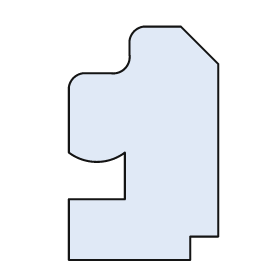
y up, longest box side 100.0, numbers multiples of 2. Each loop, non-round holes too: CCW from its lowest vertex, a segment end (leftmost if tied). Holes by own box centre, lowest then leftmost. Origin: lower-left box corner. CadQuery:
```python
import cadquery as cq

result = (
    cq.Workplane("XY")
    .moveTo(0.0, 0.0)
    .lineTo(52.0, 0.0)
    .lineTo(52.0, 10.0)
    .lineTo(64.0, 10.0)
    .lineTo(64.0, 84.0)
    .lineTo(48.0, 100.0)
    .lineTo(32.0, 100.0)
    .threePointArc((28.0, 98.0), (26.0, 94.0))
    .lineTo(26.0, 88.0)
    .threePointArc((24.0, 82.0), (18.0, 80.0))
    .lineTo(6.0, 80.0)
    .threePointArc((2.0, 78.0), (0.0, 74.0))
    .lineTo(0.0, 46.0)
    .threePointArc((12.0, 42.0), (24.0, 46.0))
    .lineTo(24.0, 26.0)
    .lineTo(0.0, 26.0)
    .close()
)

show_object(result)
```